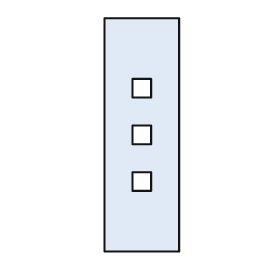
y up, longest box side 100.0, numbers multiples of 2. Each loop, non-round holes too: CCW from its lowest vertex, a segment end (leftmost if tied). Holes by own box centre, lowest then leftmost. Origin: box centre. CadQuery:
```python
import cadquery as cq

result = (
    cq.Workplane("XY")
    .moveTo(-16.0, -50.0)
    .lineTo(16.0, -50.0)
    .lineTo(16.0, 50.0)
    .lineTo(-16.0, 50.0)
    .close()
    .moveTo(-4.0, -24.0)
    .lineTo(4.0, -24.0)
    .lineTo(4.0, -16.0)
    .lineTo(-4.0, -16.0)
    .close()
    .moveTo(-4.0, -4.0)
    .lineTo(4.0, -4.0)
    .lineTo(4.0, 4.0)
    .lineTo(-4.0, 4.0)
    .close()
    .moveTo(-4.0, 16.0)
    .lineTo(4.0, 16.0)
    .lineTo(4.0, 24.0)
    .lineTo(-4.0, 24.0)
    .close()
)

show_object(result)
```